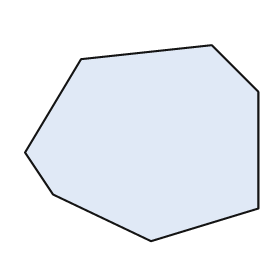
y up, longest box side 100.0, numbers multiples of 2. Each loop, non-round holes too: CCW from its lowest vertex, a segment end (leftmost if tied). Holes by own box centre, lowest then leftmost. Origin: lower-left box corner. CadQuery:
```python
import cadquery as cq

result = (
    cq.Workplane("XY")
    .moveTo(54.0, 0.0)
    .lineTo(100.0, 14.0)
    .lineTo(100.0, 64.0)
    .lineTo(80.0, 84.0)
    .lineTo(24.0, 78.0)
    .lineTo(0.0, 38.0)
    .lineTo(12.0, 20.0)
    .close()
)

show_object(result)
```